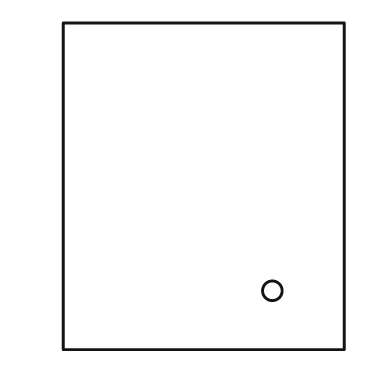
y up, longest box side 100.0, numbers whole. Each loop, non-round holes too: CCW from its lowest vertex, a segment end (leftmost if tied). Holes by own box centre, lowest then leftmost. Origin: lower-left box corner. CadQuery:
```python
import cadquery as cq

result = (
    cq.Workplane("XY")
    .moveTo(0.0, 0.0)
    .lineTo(86.0, 0.0)
    .lineTo(86.0, 100.0)
    .lineTo(0.0, 100.0)
    .close()
    .moveTo(64.0, 18.0)
    .circle(3.0)
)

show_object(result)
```